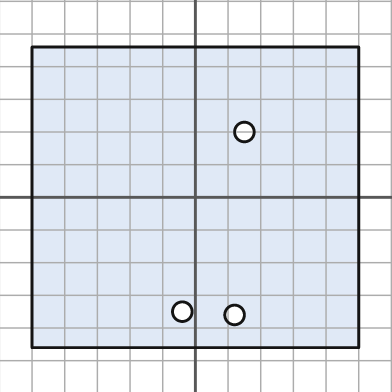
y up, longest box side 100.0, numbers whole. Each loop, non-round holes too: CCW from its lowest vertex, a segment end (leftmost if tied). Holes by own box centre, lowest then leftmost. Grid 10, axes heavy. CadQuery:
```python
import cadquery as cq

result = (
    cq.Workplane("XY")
    .moveTo(-50.0, -46.0)
    .lineTo(50.0, -46.0)
    .lineTo(50.0, 46.0)
    .lineTo(-50.0, 46.0)
    .close()
    .moveTo(12.0, -36.0)
    .circle(3.0)
    .moveTo(-4.0, -35.0)
    .circle(3.0)
    .moveTo(15.0, 20.0)
    .circle(3.0)
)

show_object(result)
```